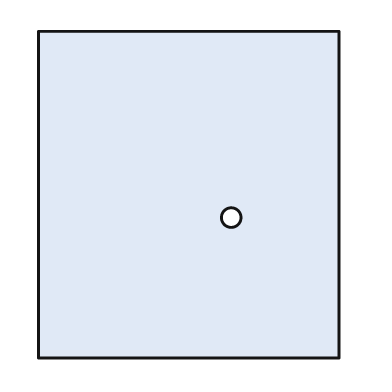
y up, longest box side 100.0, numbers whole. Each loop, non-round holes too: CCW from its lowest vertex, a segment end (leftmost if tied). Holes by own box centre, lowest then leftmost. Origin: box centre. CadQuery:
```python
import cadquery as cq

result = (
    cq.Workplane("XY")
    .moveTo(-46.0, -50.0)
    .lineTo(46.0, -50.0)
    .lineTo(46.0, 50.0)
    .lineTo(-46.0, 50.0)
    .close()
    .moveTo(13.0, -7.0)
    .circle(3.0)
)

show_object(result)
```